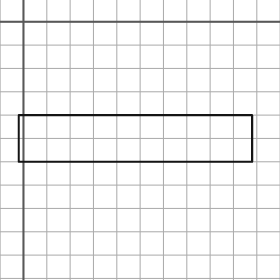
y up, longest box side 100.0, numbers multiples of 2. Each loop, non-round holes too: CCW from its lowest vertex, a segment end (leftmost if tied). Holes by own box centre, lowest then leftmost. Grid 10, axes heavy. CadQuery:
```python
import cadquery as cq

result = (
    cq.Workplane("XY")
    .moveTo(-2.0, -60.0)
    .lineTo(98.0, -60.0)
    .lineTo(98.0, -40.0)
    .lineTo(-2.0, -40.0)
    .close()
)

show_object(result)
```